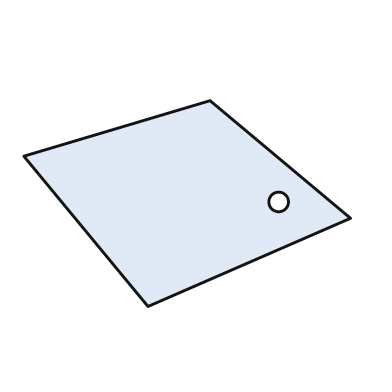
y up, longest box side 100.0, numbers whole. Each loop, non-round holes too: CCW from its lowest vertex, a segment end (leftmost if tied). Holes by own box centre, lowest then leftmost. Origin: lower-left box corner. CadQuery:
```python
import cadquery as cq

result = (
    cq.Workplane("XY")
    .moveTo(38.0, 0.0)
    .lineTo(100.0, 27.0)
    .lineTo(57.0, 63.0)
    .lineTo(0.0, 46.0)
    .close()
    .moveTo(78.0, 32.0)
    .circle(3.0)
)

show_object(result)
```